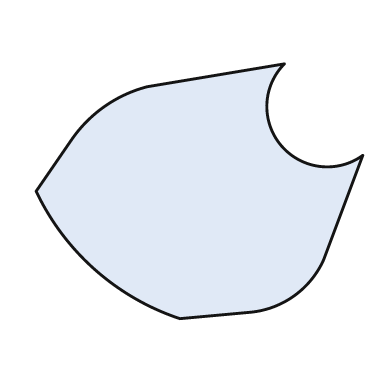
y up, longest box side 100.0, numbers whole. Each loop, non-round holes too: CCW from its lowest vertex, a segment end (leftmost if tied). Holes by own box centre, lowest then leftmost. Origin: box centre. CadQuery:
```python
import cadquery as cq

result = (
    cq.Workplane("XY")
    .moveTo(-6.0, -39.0)
    .lineTo(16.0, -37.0)
    .threePointArc((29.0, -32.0), (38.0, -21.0))
    .lineTo(50.0, 11.0)
    .threePointArc((25.0, 14.0), (26.0, 39.0))
    .lineTo(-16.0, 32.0)
    .threePointArc((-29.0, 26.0), (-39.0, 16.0))
    .lineTo(-50.0, 0.0)
    .threePointArc((-32.0, -24.0), (-6.0, -39.0))
    .close()
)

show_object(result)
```